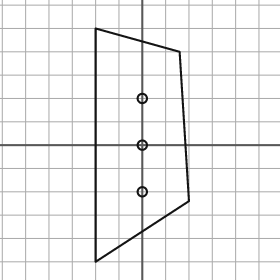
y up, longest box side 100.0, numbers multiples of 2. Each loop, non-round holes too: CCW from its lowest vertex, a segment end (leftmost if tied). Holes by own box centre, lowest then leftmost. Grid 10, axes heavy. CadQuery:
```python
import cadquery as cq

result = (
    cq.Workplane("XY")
    .moveTo(-20.0, -50.0)
    .lineTo(20.0, -24.0)
    .lineTo(16.0, 40.0)
    .lineTo(-20.0, 50.0)
    .close()
    .moveTo(0.0, -20.0)
    .circle(2.0)
    .moveTo(0.0, 0.0)
    .circle(2.0)
    .moveTo(0.0, 20.0)
    .circle(2.0)
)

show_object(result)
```